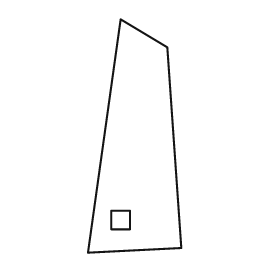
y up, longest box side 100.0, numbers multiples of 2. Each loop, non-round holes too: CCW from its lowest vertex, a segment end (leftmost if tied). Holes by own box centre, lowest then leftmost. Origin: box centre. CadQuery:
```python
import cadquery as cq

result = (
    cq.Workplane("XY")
    .moveTo(-20.0, -50.0)
    .lineTo(20.0, -48.0)
    .lineTo(14.0, 38.0)
    .lineTo(-6.0, 50.0)
    .close()
    .moveTo(-10.0, -40.0)
    .lineTo(-2.0, -40.0)
    .lineTo(-2.0, -32.0)
    .lineTo(-10.0, -32.0)
    .close()
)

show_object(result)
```